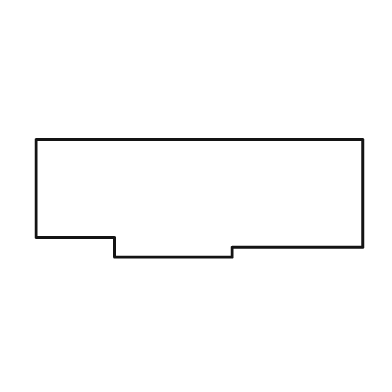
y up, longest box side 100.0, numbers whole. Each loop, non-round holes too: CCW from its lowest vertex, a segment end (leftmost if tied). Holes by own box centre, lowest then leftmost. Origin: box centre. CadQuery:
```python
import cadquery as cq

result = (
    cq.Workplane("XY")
    .moveTo(-26.0, -18.0)
    .lineTo(10.0, -18.0)
    .lineTo(10.0, -15.0)
    .lineTo(50.0, -15.0)
    .lineTo(50.0, 18.0)
    .lineTo(-50.0, 18.0)
    .lineTo(-50.0, -12.0)
    .lineTo(-26.0, -12.0)
    .close()
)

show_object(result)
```